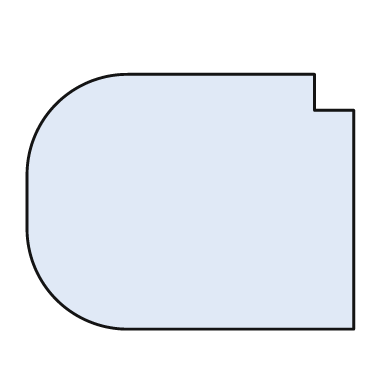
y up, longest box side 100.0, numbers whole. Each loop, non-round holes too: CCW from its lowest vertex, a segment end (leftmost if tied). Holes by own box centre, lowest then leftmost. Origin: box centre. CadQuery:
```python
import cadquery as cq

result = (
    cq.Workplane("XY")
    .moveTo(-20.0, -39.0)
    .lineTo(50.0, -39.0)
    .lineTo(50.0, 28.0)
    .lineTo(38.0, 28.0)
    .lineTo(38.0, 39.0)
    .lineTo(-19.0, 39.0)
    .threePointArc((-41.0, 30.0), (-50.0, 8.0))
    .lineTo(-50.0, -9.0)
    .threePointArc((-41.0, -30.0), (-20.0, -39.0))
    .close()
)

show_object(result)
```